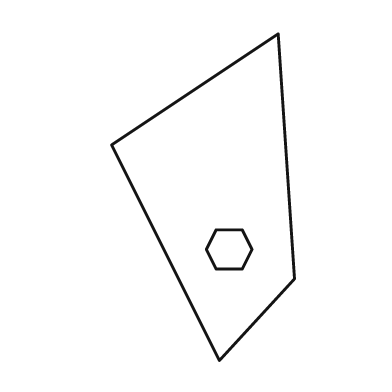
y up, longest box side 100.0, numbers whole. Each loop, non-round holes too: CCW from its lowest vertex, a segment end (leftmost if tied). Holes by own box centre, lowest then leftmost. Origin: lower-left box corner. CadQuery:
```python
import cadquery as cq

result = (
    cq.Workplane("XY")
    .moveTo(33.0, 0.0)
    .lineTo(56.0, 25.0)
    .lineTo(51.0, 100.0)
    .lineTo(0.0, 66.0)
    .close()
    .moveTo(32.0, 28.0)
    .lineTo(40.0, 28.0)
    .lineTo(43.0, 34.0)
    .lineTo(40.0, 40.0)
    .lineTo(32.0, 40.0)
    .lineTo(29.0, 34.0)
    .close()
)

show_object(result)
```